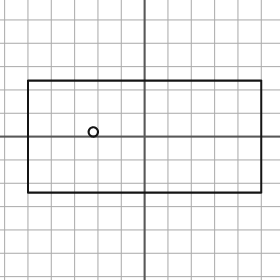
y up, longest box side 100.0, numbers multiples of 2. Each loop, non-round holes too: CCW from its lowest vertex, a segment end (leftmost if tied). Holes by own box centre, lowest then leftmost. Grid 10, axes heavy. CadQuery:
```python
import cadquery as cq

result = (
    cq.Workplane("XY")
    .moveTo(-50.0, -24.0)
    .lineTo(50.0, -24.0)
    .lineTo(50.0, 24.0)
    .lineTo(-50.0, 24.0)
    .close()
    .moveTo(-22.0, 2.0)
    .circle(2.0)
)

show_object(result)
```